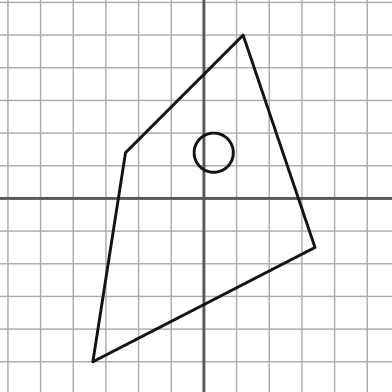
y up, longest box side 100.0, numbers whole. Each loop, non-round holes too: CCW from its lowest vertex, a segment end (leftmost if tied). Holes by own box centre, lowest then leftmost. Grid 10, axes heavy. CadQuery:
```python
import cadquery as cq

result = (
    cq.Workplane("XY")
    .moveTo(-34.0, -50.0)
    .lineTo(34.0, -15.0)
    .lineTo(12.0, 50.0)
    .lineTo(-24.0, 14.0)
    .close()
    .moveTo(3.0, 14.0)
    .circle(6.0)
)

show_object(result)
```